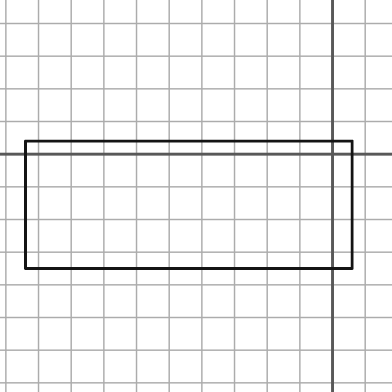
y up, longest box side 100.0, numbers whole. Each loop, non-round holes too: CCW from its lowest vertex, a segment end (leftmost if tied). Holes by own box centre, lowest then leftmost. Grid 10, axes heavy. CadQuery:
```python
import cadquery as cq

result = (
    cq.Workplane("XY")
    .moveTo(-94.0, -35.0)
    .lineTo(6.0, -35.0)
    .lineTo(6.0, 4.0)
    .lineTo(-94.0, 4.0)
    .close()
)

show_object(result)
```